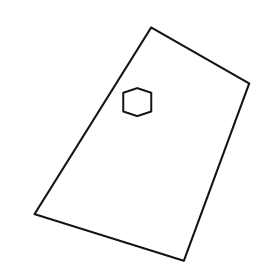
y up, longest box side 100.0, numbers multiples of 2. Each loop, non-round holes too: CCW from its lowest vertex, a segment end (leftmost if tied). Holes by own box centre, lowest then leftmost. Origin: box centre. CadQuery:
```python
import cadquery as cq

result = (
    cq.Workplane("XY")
    .moveTo(18.0, -50.0)
    .lineTo(46.0, 26.0)
    .lineTo(4.0, 50.0)
    .lineTo(-46.0, -30.0)
    .close()
    .moveTo(-2.0, 12.0)
    .lineTo(4.0, 14.0)
    .lineTo(4.0, 22.0)
    .lineTo(-2.0, 24.0)
    .lineTo(-8.0, 22.0)
    .lineTo(-8.0, 14.0)
    .close()
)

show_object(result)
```